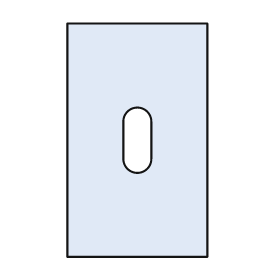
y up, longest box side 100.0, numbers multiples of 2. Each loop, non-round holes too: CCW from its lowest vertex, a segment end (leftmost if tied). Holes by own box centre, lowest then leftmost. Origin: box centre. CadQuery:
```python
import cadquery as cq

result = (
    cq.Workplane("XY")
    .moveTo(-30.0, -50.0)
    .lineTo(30.0, -50.0)
    .lineTo(30.0, 50.0)
    .lineTo(-30.0, 50.0)
    .close()
    .moveTo(-6.0, -8.0)
    .threePointArc((0.0, -14.0), (6.0, -8.0))
    .lineTo(6.0, 8.0)
    .threePointArc((0.0, 14.0), (-6.0, 8.0))
    .close()
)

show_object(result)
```